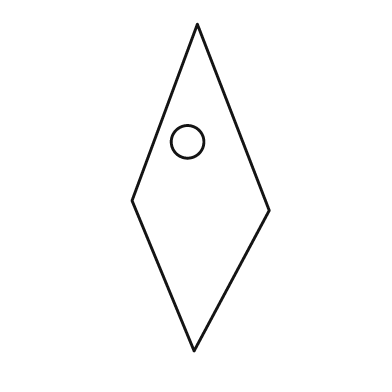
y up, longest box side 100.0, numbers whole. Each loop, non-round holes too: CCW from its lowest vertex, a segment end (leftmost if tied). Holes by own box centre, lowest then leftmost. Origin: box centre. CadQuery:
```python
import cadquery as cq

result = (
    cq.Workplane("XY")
    .moveTo(-2.0, -50.0)
    .lineTo(21.0, -7.0)
    .lineTo(-1.0, 50.0)
    .lineTo(-21.0, -4.0)
    .close()
    .moveTo(-4.0, 14.0)
    .circle(5.0)
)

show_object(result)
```